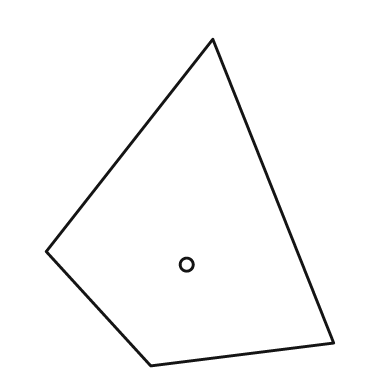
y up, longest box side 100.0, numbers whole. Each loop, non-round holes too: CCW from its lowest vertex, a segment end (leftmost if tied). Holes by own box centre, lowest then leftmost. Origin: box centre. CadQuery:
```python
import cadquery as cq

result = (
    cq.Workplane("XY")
    .moveTo(-12.0, -50.0)
    .lineTo(44.0, -43.0)
    .lineTo(7.0, 50.0)
    .lineTo(-44.0, -15.0)
    .close()
    .moveTo(-1.0, -19.0)
    .circle(2.0)
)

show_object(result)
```